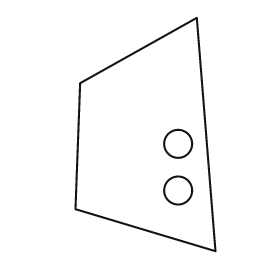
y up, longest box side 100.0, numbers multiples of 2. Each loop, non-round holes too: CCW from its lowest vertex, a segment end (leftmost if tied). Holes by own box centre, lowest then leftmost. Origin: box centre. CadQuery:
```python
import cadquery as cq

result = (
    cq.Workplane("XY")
    .moveTo(30.0, -50.0)
    .lineTo(22.0, 50.0)
    .lineTo(-28.0, 22.0)
    .lineTo(-30.0, -32.0)
    .close()
    .moveTo(14.0, -24.0)
    .circle(6.0)
    .moveTo(14.0, -4.0)
    .circle(6.0)
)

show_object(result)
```